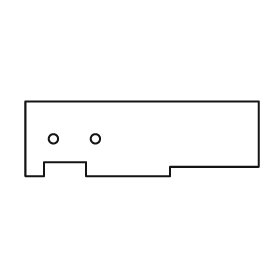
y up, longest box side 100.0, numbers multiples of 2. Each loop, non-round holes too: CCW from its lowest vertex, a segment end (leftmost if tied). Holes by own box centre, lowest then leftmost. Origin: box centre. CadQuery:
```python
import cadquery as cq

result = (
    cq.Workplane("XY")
    .moveTo(-50.0, -16.0)
    .lineTo(-42.0, -16.0)
    .lineTo(-42.0, -10.0)
    .lineTo(-24.0, -10.0)
    .lineTo(-24.0, -16.0)
    .lineTo(12.0, -16.0)
    .lineTo(12.0, -12.0)
    .lineTo(50.0, -12.0)
    .lineTo(50.0, 16.0)
    .lineTo(-50.0, 16.0)
    .close()
    .moveTo(-38.0, 0.0)
    .circle(2.0)
    .moveTo(-20.0, 0.0)
    .circle(2.0)
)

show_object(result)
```